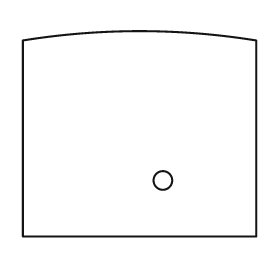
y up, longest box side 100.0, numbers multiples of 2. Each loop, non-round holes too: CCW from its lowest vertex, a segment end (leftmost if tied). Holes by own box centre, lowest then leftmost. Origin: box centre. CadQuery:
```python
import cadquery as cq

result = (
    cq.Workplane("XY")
    .moveTo(-50.0, -44.0)
    .lineTo(50.0, -44.0)
    .lineTo(50.0, 40.0)
    .threePointArc((0.0, 44.0), (-50.0, 40.0))
    .close()
    .moveTo(10.0, -20.0)
    .circle(4.0)
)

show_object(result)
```